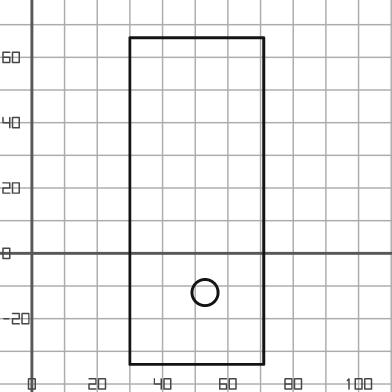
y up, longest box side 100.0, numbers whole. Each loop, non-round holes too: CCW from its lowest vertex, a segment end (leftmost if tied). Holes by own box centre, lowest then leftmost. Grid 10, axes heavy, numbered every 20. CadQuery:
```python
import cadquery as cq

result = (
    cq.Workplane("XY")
    .moveTo(30.0, -34.0)
    .lineTo(71.0, -34.0)
    .lineTo(71.0, 66.0)
    .lineTo(30.0, 66.0)
    .close()
    .moveTo(53.0, -12.0)
    .circle(4.0)
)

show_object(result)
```